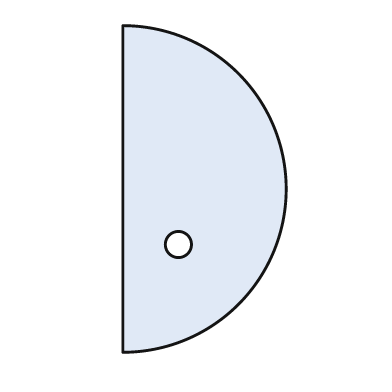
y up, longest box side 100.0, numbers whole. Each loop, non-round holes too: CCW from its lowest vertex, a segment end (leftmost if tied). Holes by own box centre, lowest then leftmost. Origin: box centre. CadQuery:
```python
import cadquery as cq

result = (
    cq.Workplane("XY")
    .moveTo(-25.0, -50.0)
    .threePointArc((25.0, 0.0), (-25.0, 50.0))
    .close()
    .moveTo(-8.0, -17.0)
    .circle(4.0)
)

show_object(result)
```